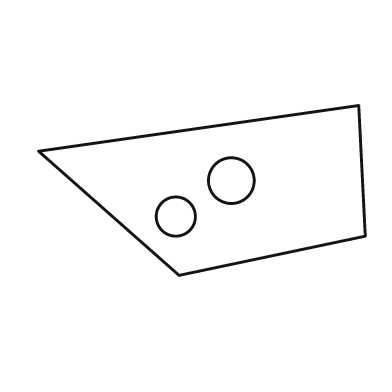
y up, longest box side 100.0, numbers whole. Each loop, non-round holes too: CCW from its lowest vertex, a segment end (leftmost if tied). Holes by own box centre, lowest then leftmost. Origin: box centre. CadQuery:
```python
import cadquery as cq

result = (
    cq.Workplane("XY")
    .moveTo(-7.0, -26.0)
    .lineTo(50.0, -14.0)
    .lineTo(48.0, 26.0)
    .lineTo(-50.0, 12.0)
    .close()
    .moveTo(-8.0, -8.0)
    .circle(6.0)
    .moveTo(9.0, 3.0)
    .circle(7.0)
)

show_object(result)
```